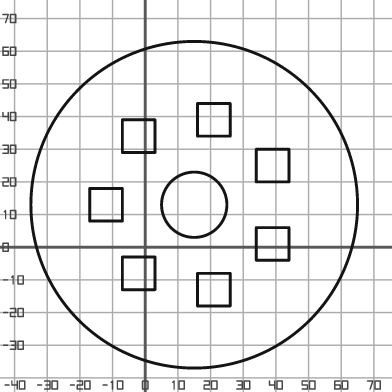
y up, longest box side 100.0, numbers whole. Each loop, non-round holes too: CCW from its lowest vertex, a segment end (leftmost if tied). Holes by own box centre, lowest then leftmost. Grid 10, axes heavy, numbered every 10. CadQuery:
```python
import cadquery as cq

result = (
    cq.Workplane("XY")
    .moveTo(15.0, 13.0)
    .circle(50.0)
    .moveTo(16.0, -18.0)
    .lineTo(26.0, -18.0)
    .lineTo(26.0, -8.0)
    .lineTo(16.0, -8.0)
    .close()
    .moveTo(-7.0, -13.0)
    .lineTo(3.0, -13.0)
    .lineTo(3.0, -3.0)
    .lineTo(-7.0, -3.0)
    .close()
    .moveTo(34.0, -4.0)
    .lineTo(44.0, -4.0)
    .lineTo(44.0, 6.0)
    .lineTo(34.0, 6.0)
    .close()
    .moveTo(-17.0, 8.0)
    .lineTo(-7.0, 8.0)
    .lineTo(-7.0, 18.0)
    .lineTo(-17.0, 18.0)
    .close()
    .moveTo(15.0, 13.0)
    .circle(10.0)
    .moveTo(34.0, 20.0)
    .lineTo(44.0, 20.0)
    .lineTo(44.0, 30.0)
    .lineTo(34.0, 30.0)
    .close()
    .moveTo(-7.0, 29.0)
    .lineTo(3.0, 29.0)
    .lineTo(3.0, 39.0)
    .lineTo(-7.0, 39.0)
    .close()
    .moveTo(16.0, 34.0)
    .lineTo(26.0, 34.0)
    .lineTo(26.0, 44.0)
    .lineTo(16.0, 44.0)
    .close()
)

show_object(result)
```